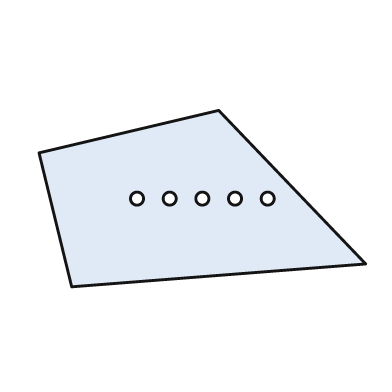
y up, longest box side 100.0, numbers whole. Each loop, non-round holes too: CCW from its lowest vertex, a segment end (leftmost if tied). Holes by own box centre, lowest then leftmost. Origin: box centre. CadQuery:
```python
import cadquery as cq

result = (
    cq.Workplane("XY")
    .moveTo(-40.0, -27.0)
    .lineTo(50.0, -20.0)
    .lineTo(5.0, 27.0)
    .lineTo(-50.0, 14.0)
    .close()
    .moveTo(-20.0, 0.0)
    .circle(2.0)
    .moveTo(-10.0, 0.0)
    .circle(2.0)
    .moveTo(0.0, 0.0)
    .circle(2.0)
    .moveTo(10.0, 0.0)
    .circle(2.0)
    .moveTo(20.0, 0.0)
    .circle(2.0)
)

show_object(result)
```